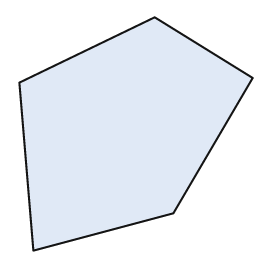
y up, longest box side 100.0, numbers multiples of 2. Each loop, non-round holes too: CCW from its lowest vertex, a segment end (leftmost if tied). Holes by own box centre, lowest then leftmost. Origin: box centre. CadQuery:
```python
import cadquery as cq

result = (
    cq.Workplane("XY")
    .moveTo(-44.0, -50.0)
    .lineTo(16.0, -34.0)
    .lineTo(50.0, 24.0)
    .lineTo(8.0, 50.0)
    .lineTo(-50.0, 22.0)
    .close()
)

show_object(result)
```